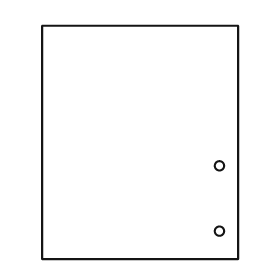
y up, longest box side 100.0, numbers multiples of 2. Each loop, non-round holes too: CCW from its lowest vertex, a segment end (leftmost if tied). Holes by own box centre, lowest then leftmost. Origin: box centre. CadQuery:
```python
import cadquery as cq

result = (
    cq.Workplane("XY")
    .moveTo(-42.0, -50.0)
    .lineTo(42.0, -50.0)
    .lineTo(42.0, 50.0)
    .lineTo(-42.0, 50.0)
    .close()
    .moveTo(34.0, -38.0)
    .circle(2.0)
    .moveTo(34.0, -10.0)
    .circle(2.0)
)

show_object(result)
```